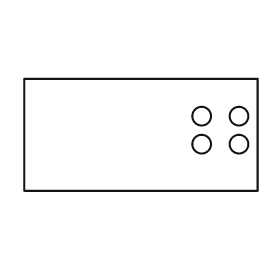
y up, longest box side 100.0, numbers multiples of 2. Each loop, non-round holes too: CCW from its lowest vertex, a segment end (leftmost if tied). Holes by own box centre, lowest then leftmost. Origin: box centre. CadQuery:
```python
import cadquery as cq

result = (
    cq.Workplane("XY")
    .moveTo(-50.0, -24.0)
    .lineTo(50.0, -24.0)
    .lineTo(50.0, 24.0)
    .lineTo(-50.0, 24.0)
    .close()
    .moveTo(26.0, -4.0)
    .circle(4.0)
    .moveTo(42.0, -4.0)
    .circle(4.0)
    .moveTo(26.0, 8.0)
    .circle(4.0)
    .moveTo(42.0, 8.0)
    .circle(4.0)
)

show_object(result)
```